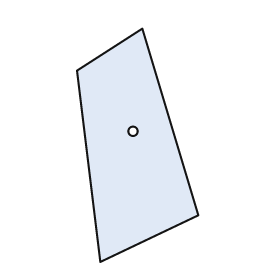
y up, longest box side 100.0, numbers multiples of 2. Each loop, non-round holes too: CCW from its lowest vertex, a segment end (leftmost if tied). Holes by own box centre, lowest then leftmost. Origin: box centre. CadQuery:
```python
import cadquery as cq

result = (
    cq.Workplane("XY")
    .moveTo(-16.0, -50.0)
    .lineTo(26.0, -30.0)
    .lineTo(2.0, 50.0)
    .lineTo(-26.0, 32.0)
    .close()
    .moveTo(-2.0, 6.0)
    .circle(2.0)
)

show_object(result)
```